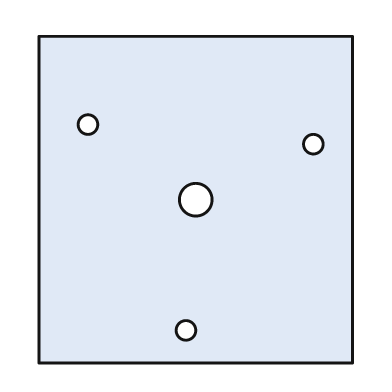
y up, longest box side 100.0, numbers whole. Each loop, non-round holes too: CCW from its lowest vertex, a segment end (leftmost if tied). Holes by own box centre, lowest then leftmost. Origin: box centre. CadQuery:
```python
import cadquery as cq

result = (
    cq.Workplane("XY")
    .moveTo(-48.0, -50.0)
    .lineTo(48.0, -50.0)
    .lineTo(48.0, 50.0)
    .lineTo(-48.0, 50.0)
    .close()
    .moveTo(-3.0, -40.0)
    .circle(3.0)
    .moveTo(0.0, 0.0)
    .circle(5.0)
    .moveTo(36.0, 17.0)
    .circle(3.0)
    .moveTo(-33.0, 23.0)
    .circle(3.0)
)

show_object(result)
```